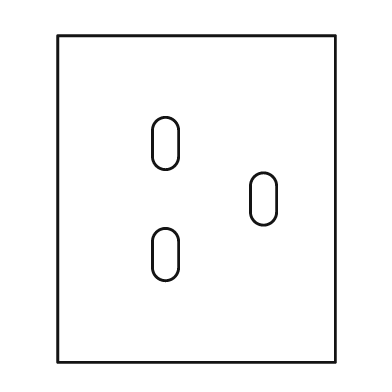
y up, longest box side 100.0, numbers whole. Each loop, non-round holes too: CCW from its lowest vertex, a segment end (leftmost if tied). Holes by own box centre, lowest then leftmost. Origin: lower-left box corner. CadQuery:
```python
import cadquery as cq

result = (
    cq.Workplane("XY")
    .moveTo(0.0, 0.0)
    .lineTo(85.0, 0.0)
    .lineTo(85.0, 100.0)
    .lineTo(0.0, 100.0)
    .close()
    .moveTo(29.0, 29.0)
    .threePointArc((33.0, 25.0), (37.0, 29.0))
    .lineTo(37.0, 37.0)
    .threePointArc((33.0, 41.0), (29.0, 37.0))
    .close()
    .moveTo(59.0, 46.0)
    .threePointArc((63.0, 42.0), (67.0, 46.0))
    .lineTo(67.0, 54.0)
    .threePointArc((63.0, 58.0), (59.0, 54.0))
    .close()
    .moveTo(29.0, 63.0)
    .threePointArc((33.0, 59.0), (37.0, 63.0))
    .lineTo(37.0, 71.0)
    .threePointArc((33.0, 75.0), (29.0, 71.0))
    .close()
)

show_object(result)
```